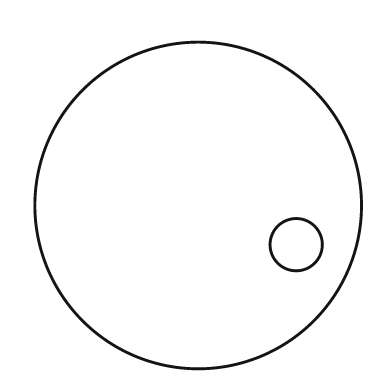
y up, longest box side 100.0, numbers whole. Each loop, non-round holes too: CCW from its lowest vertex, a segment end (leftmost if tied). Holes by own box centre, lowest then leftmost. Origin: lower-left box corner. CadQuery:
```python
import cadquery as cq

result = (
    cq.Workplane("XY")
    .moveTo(50.0, 50.0)
    .circle(50.0)
    .moveTo(80.0, 38.0)
    .circle(8.0)
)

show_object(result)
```